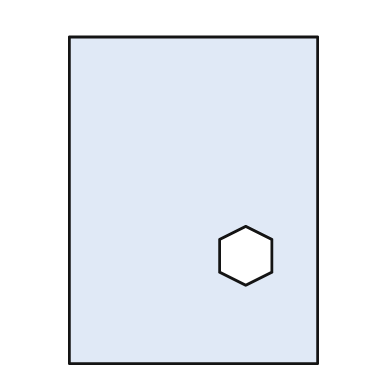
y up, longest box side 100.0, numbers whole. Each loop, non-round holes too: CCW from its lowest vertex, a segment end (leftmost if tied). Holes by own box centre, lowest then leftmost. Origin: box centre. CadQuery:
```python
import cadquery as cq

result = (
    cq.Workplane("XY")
    .moveTo(-38.0, -50.0)
    .lineTo(38.0, -50.0)
    .lineTo(38.0, 50.0)
    .lineTo(-38.0, 50.0)
    .close()
    .moveTo(16.0, -26.0)
    .lineTo(24.0, -22.0)
    .lineTo(24.0, -12.0)
    .lineTo(16.0, -8.0)
    .lineTo(8.0, -12.0)
    .lineTo(8.0, -22.0)
    .close()
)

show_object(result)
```